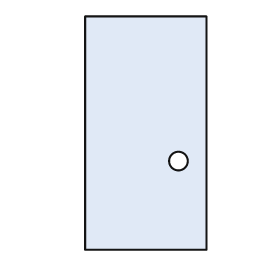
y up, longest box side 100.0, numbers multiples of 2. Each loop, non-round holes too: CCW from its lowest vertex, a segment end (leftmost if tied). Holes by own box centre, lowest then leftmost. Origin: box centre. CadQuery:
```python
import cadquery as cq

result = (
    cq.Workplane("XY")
    .moveTo(-26.0, -50.0)
    .lineTo(26.0, -50.0)
    .lineTo(26.0, 50.0)
    .lineTo(-26.0, 50.0)
    .close()
    .moveTo(14.0, -12.0)
    .circle(4.0)
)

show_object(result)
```